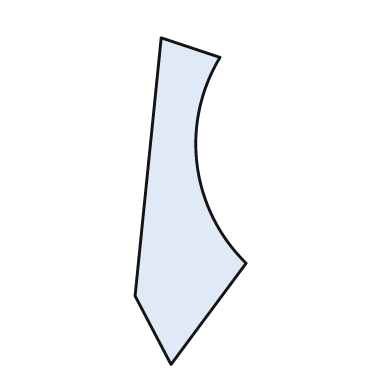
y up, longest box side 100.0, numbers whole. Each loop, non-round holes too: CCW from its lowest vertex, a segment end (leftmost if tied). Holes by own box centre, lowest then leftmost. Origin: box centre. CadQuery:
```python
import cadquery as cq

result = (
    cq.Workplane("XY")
    .moveTo(-6.0, -50.0)
    .lineTo(17.0, -19.0)
    .threePointArc((2.0, 11.0), (9.0, 44.0))
    .lineTo(-9.0, 50.0)
    .lineTo(-17.0, -29.0)
    .close()
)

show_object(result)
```